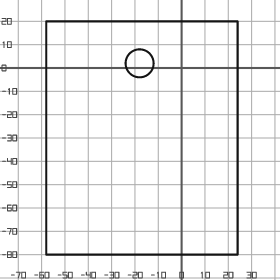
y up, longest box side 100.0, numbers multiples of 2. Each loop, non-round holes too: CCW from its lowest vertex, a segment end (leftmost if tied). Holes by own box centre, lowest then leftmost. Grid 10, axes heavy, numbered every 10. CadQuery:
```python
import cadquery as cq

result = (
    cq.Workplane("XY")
    .moveTo(-58.0, -80.0)
    .lineTo(24.0, -80.0)
    .lineTo(24.0, 20.0)
    .lineTo(-58.0, 20.0)
    .close()
    .moveTo(-18.0, 2.0)
    .circle(6.0)
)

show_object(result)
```